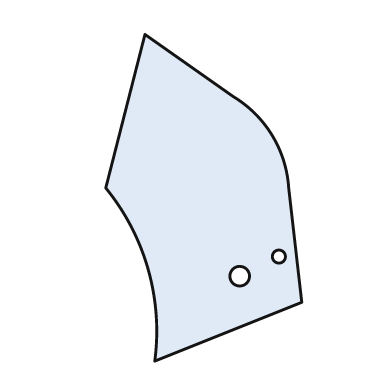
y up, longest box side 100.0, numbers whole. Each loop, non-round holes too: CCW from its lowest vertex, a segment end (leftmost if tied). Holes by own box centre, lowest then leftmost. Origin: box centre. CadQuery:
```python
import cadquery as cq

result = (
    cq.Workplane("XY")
    .moveTo(-15.0, -50.0)
    .lineTo(30.0, -32.0)
    .lineTo(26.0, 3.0)
    .threePointArc((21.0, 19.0), (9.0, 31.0))
    .lineTo(-18.0, 50.0)
    .lineTo(-30.0, 3.0)
    .threePointArc((-17.0, -22.0), (-15.0, -50.0))
    .close()
    .moveTo(11.0, -24.0)
    .circle(3.0)
    .moveTo(23.0, -18.0)
    .circle(2.0)
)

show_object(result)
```